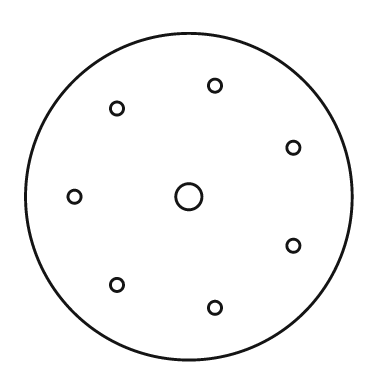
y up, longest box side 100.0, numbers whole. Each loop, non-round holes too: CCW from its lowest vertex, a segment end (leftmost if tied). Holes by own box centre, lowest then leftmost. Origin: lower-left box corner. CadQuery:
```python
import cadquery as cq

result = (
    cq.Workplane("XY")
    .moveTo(50.0, 50.0)
    .circle(50.0)
    .moveTo(58.0, 16.0)
    .circle(2.0)
    .moveTo(28.0, 23.0)
    .circle(2.0)
    .moveTo(82.0, 35.0)
    .circle(2.0)
    .moveTo(15.0, 50.0)
    .circle(2.0)
    .moveTo(50.0, 50.0)
    .circle(4.0)
    .moveTo(82.0, 65.0)
    .circle(2.0)
    .moveTo(28.0, 77.0)
    .circle(2.0)
    .moveTo(58.0, 84.0)
    .circle(2.0)
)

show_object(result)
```